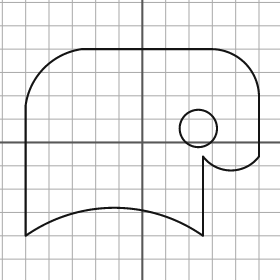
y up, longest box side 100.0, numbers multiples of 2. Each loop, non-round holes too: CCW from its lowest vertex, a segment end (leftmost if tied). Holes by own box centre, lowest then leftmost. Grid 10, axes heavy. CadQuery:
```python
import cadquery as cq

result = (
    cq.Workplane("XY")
    .moveTo(-50.0, -40.0)
    .threePointArc((-12.0, -28.0), (26.0, -40.0))
    .lineTo(26.0, -6.0)
    .threePointArc((38.0, -12.0), (50.0, -6.0))
    .lineTo(50.0, 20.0)
    .threePointArc((44.0, 34.0), (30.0, 40.0))
    .lineTo(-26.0, 40.0)
    .threePointArc((-42.0, 32.0), (-50.0, 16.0))
    .close()
    .moveTo(24.0, 6.0)
    .circle(8.0)
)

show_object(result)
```